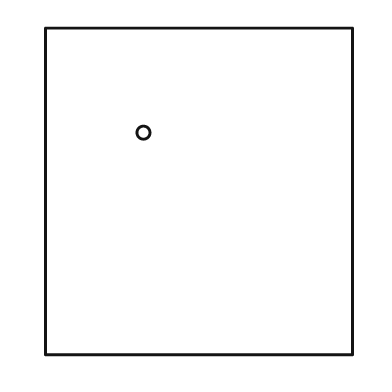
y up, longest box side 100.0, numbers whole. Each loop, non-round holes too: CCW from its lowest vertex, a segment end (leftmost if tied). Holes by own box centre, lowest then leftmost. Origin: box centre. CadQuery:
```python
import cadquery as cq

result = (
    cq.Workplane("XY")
    .moveTo(-47.0, -50.0)
    .lineTo(47.0, -50.0)
    .lineTo(47.0, 50.0)
    .lineTo(-47.0, 50.0)
    .close()
    .moveTo(-17.0, 18.0)
    .circle(2.0)
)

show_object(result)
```